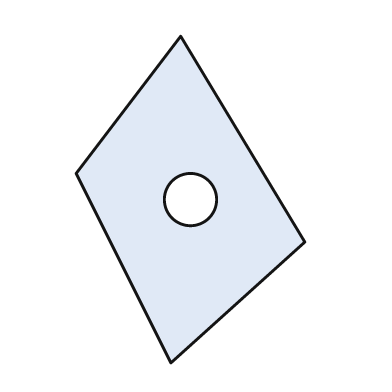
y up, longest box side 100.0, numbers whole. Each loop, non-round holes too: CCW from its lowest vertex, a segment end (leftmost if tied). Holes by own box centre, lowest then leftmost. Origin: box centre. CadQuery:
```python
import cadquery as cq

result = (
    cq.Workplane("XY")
    .moveTo(-6.0, -50.0)
    .lineTo(35.0, -13.0)
    .lineTo(-3.0, 50.0)
    .lineTo(-35.0, 8.0)
    .close()
    .moveTo(0.0, 0.0)
    .circle(8.0)
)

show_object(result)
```